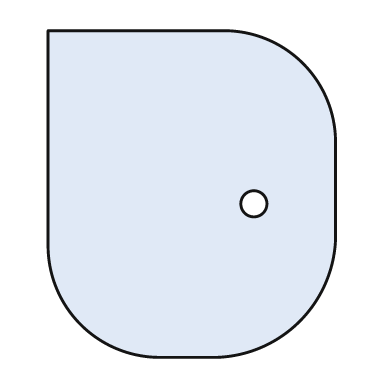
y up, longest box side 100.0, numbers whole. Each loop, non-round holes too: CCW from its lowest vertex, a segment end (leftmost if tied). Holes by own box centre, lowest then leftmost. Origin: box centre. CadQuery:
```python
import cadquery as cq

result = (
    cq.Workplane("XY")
    .moveTo(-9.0, -50.0)
    .lineTo(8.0, -50.0)
    .threePointArc((33.0, -39.0), (44.0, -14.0))
    .lineTo(44.0, 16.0)
    .threePointArc((34.0, 40.0), (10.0, 50.0))
    .lineTo(-44.0, 50.0)
    .lineTo(-44.0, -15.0)
    .threePointArc((-34.0, -40.0), (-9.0, -50.0))
    .close()
    .moveTo(19.0, -3.0)
    .circle(4.0)
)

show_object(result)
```